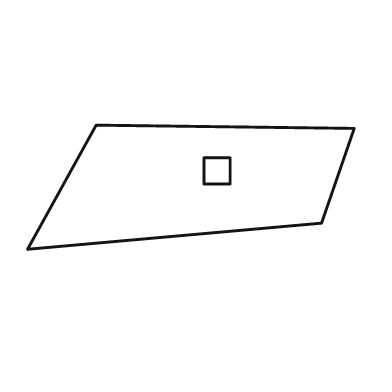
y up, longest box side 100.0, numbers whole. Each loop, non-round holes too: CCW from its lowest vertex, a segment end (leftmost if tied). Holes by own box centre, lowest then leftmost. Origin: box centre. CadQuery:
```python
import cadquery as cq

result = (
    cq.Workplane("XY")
    .moveTo(-50.0, -19.0)
    .lineTo(40.0, -11.0)
    .lineTo(50.0, 18.0)
    .lineTo(-29.0, 19.0)
    .close()
    .moveTo(4.0, 1.0)
    .lineTo(12.0, 1.0)
    .lineTo(12.0, 9.0)
    .lineTo(4.0, 9.0)
    .close()
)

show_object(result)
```